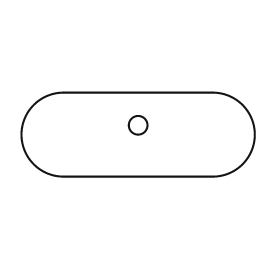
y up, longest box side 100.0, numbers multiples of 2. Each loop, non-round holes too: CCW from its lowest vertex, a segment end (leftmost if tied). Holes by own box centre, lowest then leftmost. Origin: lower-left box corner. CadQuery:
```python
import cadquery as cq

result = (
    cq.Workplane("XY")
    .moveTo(18.0, 0.0)
    .lineTo(82.0, 0.0)
    .threePointArc((100.0, 18.0), (82.0, 36.0))
    .lineTo(18.0, 36.0)
    .threePointArc((0.0, 18.0), (18.0, 0.0))
    .close()
    .moveTo(50.0, 22.0)
    .circle(4.0)
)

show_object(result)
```